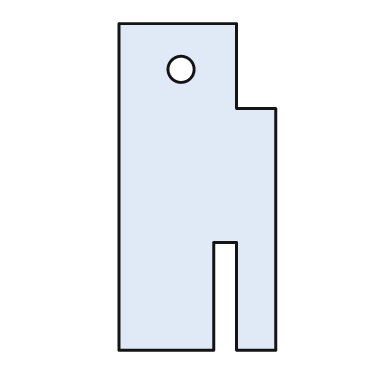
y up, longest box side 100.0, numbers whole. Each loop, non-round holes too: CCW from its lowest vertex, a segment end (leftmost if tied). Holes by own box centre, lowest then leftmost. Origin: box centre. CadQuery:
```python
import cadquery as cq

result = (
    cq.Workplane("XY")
    .moveTo(-24.0, -50.0)
    .lineTo(5.0, -50.0)
    .lineTo(5.0, -17.0)
    .lineTo(12.0, -17.0)
    .lineTo(12.0, -50.0)
    .lineTo(24.0, -50.0)
    .lineTo(24.0, 24.0)
    .lineTo(12.0, 24.0)
    .lineTo(12.0, 50.0)
    .lineTo(-24.0, 50.0)
    .close()
    .moveTo(-5.0, 36.0)
    .circle(4.0)
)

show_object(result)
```